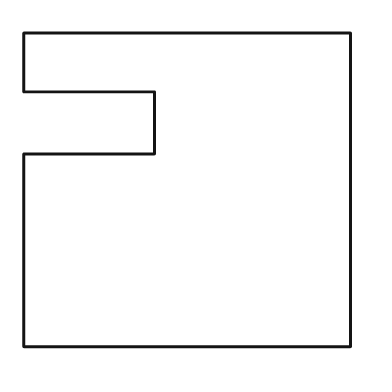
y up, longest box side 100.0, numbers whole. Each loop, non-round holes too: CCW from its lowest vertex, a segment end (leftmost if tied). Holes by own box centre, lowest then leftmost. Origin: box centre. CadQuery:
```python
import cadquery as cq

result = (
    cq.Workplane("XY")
    .moveTo(-50.0, -48.0)
    .lineTo(50.0, -48.0)
    .lineTo(50.0, 48.0)
    .lineTo(-50.0, 48.0)
    .lineTo(-50.0, 30.0)
    .lineTo(-10.0, 30.0)
    .lineTo(-10.0, 11.0)
    .lineTo(-50.0, 11.0)
    .close()
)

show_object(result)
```